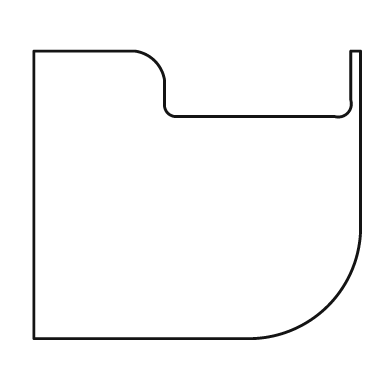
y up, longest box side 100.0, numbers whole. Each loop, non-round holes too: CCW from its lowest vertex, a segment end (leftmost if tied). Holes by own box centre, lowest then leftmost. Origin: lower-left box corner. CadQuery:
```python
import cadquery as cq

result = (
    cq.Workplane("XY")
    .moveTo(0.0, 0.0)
    .lineTo(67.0, 0.0)
    .threePointArc((90.0, 10.0), (100.0, 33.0))
    .lineTo(100.0, 88.0)
    .lineTo(97.0, 88.0)
    .lineTo(97.0, 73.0)
    .threePointArc((96.0, 69.0), (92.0, 68.0))
    .lineTo(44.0, 68.0)
    .threePointArc((41.0, 69.0), (40.0, 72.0))
    .lineTo(40.0, 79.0)
    .threePointArc((37.0, 85.0), (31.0, 88.0))
    .lineTo(0.0, 88.0)
    .close()
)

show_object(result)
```